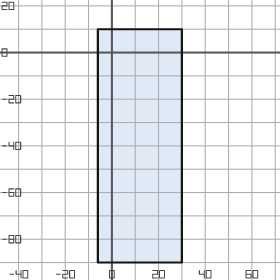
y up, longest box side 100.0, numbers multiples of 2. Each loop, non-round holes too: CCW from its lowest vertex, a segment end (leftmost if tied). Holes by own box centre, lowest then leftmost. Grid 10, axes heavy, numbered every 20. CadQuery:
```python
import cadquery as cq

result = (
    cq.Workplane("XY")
    .moveTo(-6.0, -90.0)
    .lineTo(30.0, -90.0)
    .lineTo(30.0, 10.0)
    .lineTo(-6.0, 10.0)
    .close()
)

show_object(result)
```